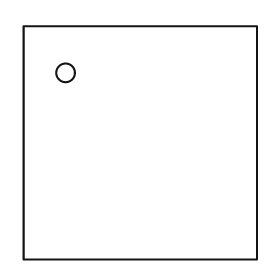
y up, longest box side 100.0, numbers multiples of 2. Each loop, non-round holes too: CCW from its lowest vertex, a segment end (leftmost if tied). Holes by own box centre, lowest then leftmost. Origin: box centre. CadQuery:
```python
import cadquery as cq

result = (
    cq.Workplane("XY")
    .moveTo(-50.0, -50.0)
    .lineTo(50.0, -50.0)
    .lineTo(50.0, 50.0)
    .lineTo(-50.0, 50.0)
    .close()
    .moveTo(-32.0, 30.0)
    .circle(4.0)
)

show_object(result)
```